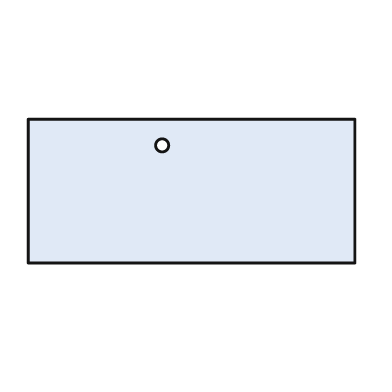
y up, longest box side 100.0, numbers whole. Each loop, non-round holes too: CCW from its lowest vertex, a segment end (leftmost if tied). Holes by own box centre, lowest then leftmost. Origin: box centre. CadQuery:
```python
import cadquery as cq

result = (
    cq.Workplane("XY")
    .moveTo(-50.0, -22.0)
    .lineTo(50.0, -22.0)
    .lineTo(50.0, 22.0)
    .lineTo(-50.0, 22.0)
    .close()
    .moveTo(-9.0, 14.0)
    .circle(2.0)
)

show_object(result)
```